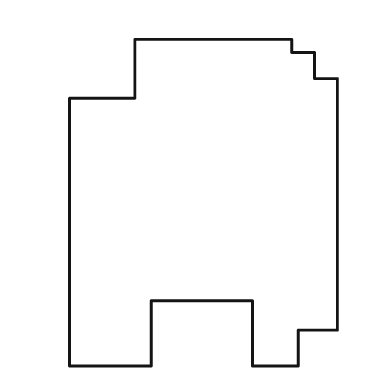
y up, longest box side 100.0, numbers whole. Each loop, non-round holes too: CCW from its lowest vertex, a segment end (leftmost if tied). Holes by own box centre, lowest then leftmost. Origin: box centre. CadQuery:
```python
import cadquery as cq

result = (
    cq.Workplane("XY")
    .moveTo(-41.0, -50.0)
    .lineTo(-16.0, -50.0)
    .lineTo(-16.0, -30.0)
    .lineTo(15.0, -30.0)
    .lineTo(15.0, -50.0)
    .lineTo(29.0, -50.0)
    .lineTo(29.0, -39.0)
    .lineTo(41.0, -39.0)
    .lineTo(41.0, 38.0)
    .lineTo(34.0, 38.0)
    .lineTo(34.0, 46.0)
    .lineTo(27.0, 46.0)
    .lineTo(27.0, 50.0)
    .lineTo(-21.0, 50.0)
    .lineTo(-21.0, 32.0)
    .lineTo(-41.0, 32.0)
    .close()
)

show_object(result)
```